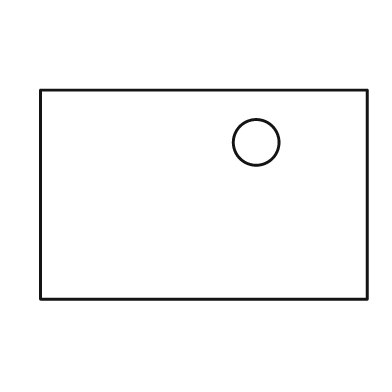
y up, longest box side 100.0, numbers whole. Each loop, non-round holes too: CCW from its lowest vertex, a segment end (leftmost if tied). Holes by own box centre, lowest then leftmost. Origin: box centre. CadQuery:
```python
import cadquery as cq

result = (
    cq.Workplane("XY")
    .moveTo(-50.0, -32.0)
    .lineTo(50.0, -32.0)
    .lineTo(50.0, 32.0)
    .lineTo(-50.0, 32.0)
    .close()
    .moveTo(16.0, 16.0)
    .circle(7.0)
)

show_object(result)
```